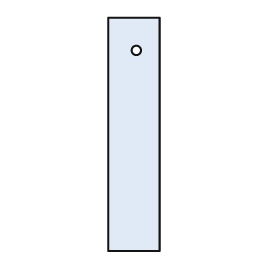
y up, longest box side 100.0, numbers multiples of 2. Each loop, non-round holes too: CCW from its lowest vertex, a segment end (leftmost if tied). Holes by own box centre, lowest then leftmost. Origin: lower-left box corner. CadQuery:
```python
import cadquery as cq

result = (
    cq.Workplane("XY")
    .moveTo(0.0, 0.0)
    .lineTo(22.0, 0.0)
    .lineTo(22.0, 100.0)
    .lineTo(0.0, 100.0)
    .close()
    .moveTo(12.0, 86.0)
    .circle(2.0)
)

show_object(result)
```